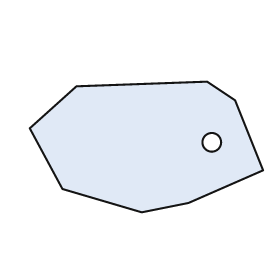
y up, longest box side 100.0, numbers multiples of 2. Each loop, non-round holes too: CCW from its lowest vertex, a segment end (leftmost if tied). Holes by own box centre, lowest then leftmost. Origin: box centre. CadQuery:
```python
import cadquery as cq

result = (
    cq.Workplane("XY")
    .moveTo(-2.0, -28.0)
    .lineTo(18.0, -24.0)
    .lineTo(50.0, -10.0)
    .lineTo(38.0, 20.0)
    .lineTo(26.0, 28.0)
    .lineTo(-30.0, 26.0)
    .lineTo(-50.0, 8.0)
    .lineTo(-36.0, -18.0)
    .close()
    .moveTo(28.0, 2.0)
    .circle(4.0)
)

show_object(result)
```